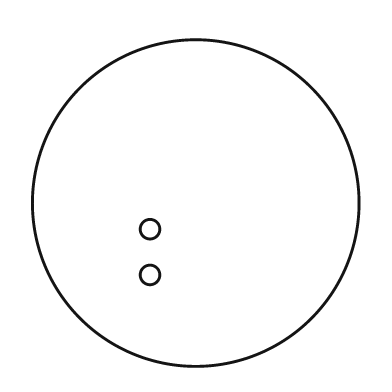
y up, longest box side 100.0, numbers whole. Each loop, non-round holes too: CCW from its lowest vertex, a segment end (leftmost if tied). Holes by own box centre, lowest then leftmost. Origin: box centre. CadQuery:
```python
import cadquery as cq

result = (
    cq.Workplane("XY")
    .moveTo(0.0, 0.0)
    .circle(50.0)
    .moveTo(-14.0, -22.0)
    .circle(3.0)
    .moveTo(-14.0, -8.0)
    .circle(3.0)
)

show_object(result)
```